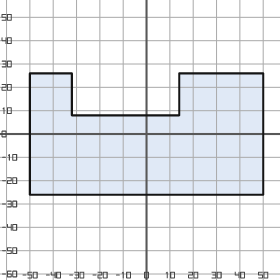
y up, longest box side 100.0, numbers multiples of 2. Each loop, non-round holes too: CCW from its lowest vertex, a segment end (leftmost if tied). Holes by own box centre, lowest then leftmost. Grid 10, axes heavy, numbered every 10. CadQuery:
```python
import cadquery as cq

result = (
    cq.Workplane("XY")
    .moveTo(-50.0, -26.0)
    .lineTo(50.0, -26.0)
    .lineTo(50.0, 26.0)
    .lineTo(14.0, 26.0)
    .lineTo(14.0, 8.0)
    .lineTo(-32.0, 8.0)
    .lineTo(-32.0, 26.0)
    .lineTo(-50.0, 26.0)
    .close()
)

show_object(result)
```